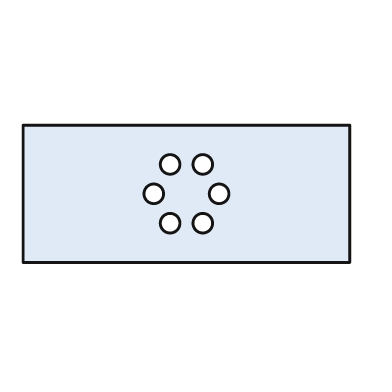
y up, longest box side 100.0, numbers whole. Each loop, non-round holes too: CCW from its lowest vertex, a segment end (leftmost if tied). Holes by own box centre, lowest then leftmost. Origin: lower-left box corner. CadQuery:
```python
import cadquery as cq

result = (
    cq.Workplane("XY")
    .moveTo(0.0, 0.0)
    .lineTo(100.0, 0.0)
    .lineTo(100.0, 42.0)
    .lineTo(0.0, 42.0)
    .close()
    .moveTo(45.0, 12.0)
    .circle(3.0)
    .moveTo(55.0, 12.0)
    .circle(3.0)
    .moveTo(40.0, 21.0)
    .circle(3.0)
    .moveTo(60.0, 21.0)
    .circle(3.0)
    .moveTo(45.0, 30.0)
    .circle(3.0)
    .moveTo(55.0, 30.0)
    .circle(3.0)
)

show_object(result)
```